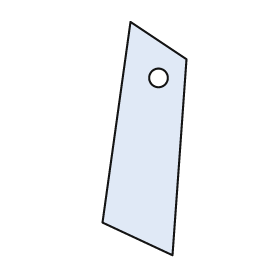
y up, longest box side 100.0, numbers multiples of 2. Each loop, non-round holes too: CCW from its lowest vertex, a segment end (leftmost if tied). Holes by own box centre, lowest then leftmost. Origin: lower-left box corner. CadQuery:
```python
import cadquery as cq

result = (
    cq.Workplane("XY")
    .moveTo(30.0, 0.0)
    .lineTo(36.0, 84.0)
    .lineTo(12.0, 100.0)
    .lineTo(0.0, 14.0)
    .close()
    .moveTo(24.0, 76.0)
    .circle(4.0)
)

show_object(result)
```